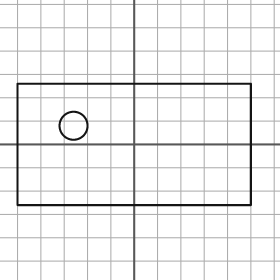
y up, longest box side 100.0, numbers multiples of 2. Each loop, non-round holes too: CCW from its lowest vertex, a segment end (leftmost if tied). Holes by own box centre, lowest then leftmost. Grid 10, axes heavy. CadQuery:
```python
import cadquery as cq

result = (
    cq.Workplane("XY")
    .moveTo(-50.0, -26.0)
    .lineTo(50.0, -26.0)
    .lineTo(50.0, 26.0)
    .lineTo(-50.0, 26.0)
    .close()
    .moveTo(-26.0, 8.0)
    .circle(6.0)
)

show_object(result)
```